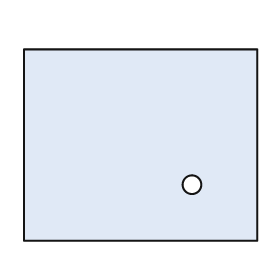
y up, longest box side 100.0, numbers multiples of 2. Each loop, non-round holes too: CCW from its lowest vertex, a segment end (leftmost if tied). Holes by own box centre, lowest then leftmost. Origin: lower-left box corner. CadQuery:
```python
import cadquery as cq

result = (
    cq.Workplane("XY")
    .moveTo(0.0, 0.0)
    .lineTo(100.0, 0.0)
    .lineTo(100.0, 82.0)
    .lineTo(0.0, 82.0)
    .close()
    .moveTo(72.0, 24.0)
    .circle(4.0)
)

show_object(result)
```